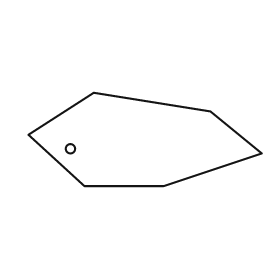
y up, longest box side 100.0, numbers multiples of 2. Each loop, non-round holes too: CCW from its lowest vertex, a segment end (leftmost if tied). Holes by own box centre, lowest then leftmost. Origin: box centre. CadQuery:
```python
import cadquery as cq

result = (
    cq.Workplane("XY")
    .moveTo(-26.0, -20.0)
    .lineTo(8.0, -20.0)
    .lineTo(50.0, -6.0)
    .lineTo(28.0, 12.0)
    .lineTo(-22.0, 20.0)
    .lineTo(-50.0, 2.0)
    .close()
    .moveTo(-32.0, -4.0)
    .circle(2.0)
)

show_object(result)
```